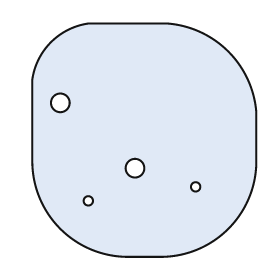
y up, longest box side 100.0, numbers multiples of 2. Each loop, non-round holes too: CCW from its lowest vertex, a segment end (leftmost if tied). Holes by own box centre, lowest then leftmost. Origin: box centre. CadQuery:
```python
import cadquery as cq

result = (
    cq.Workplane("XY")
    .moveTo(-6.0, -50.0)
    .lineTo(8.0, -50.0)
    .threePointArc((36.0, -38.0), (48.0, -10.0))
    .lineTo(48.0, 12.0)
    .threePointArc((36.0, 38.0), (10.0, 50.0))
    .lineTo(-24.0, 50.0)
    .threePointArc((-40.0, 42.0), (-48.0, 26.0))
    .lineTo(-48.0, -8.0)
    .threePointArc((-36.0, -38.0), (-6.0, -50.0))
    .close()
    .moveTo(-24.0, -26.0)
    .circle(2.0)
    .moveTo(22.0, -20.0)
    .circle(2.0)
    .moveTo(-4.0, -12.0)
    .circle(4.0)
    .moveTo(-36.0, 16.0)
    .circle(4.0)
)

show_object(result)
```